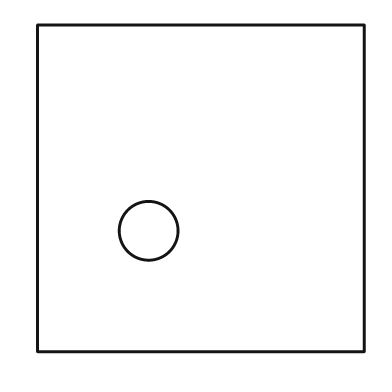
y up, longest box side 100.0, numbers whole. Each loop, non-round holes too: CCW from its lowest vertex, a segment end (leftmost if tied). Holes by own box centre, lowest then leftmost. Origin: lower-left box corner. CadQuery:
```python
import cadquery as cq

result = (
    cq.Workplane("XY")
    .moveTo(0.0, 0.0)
    .lineTo(100.0, 0.0)
    .lineTo(100.0, 100.0)
    .lineTo(0.0, 100.0)
    .close()
    .moveTo(34.0, 37.0)
    .circle(9.0)
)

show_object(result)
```